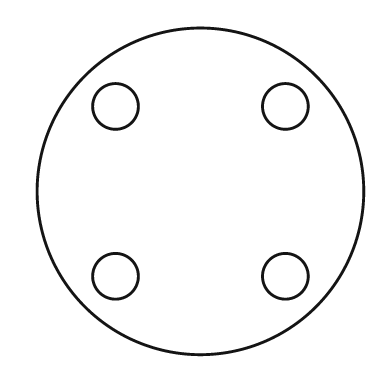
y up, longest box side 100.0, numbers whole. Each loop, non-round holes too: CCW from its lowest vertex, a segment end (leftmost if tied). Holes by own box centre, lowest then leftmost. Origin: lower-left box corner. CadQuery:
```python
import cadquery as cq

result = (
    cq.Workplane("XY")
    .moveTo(50.0, 50.0)
    .circle(50.0)
    .moveTo(24.0, 24.0)
    .circle(7.0)
    .moveTo(76.0, 24.0)
    .circle(7.0)
    .moveTo(24.0, 76.0)
    .circle(7.0)
    .moveTo(76.0, 76.0)
    .circle(7.0)
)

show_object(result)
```